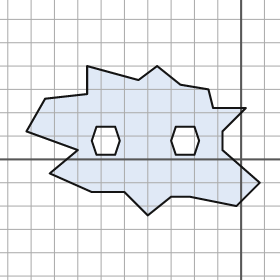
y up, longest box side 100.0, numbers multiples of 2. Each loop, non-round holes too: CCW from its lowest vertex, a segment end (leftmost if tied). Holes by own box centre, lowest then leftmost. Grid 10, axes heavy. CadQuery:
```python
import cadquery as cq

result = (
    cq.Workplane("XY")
    .moveTo(-40.0, -24.0)
    .lineTo(-30.0, -16.0)
    .lineTo(-22.0, -16.0)
    .lineTo(-2.0, -20.0)
    .lineTo(8.0, -10.0)
    .lineTo(-8.0, 4.0)
    .lineTo(-8.0, 12.0)
    .lineTo(2.0, 22.0)
    .lineTo(-12.0, 22.0)
    .lineTo(-14.0, 30.0)
    .lineTo(-26.0, 32.0)
    .lineTo(-36.0, 40.0)
    .lineTo(-44.0, 34.0)
    .lineTo(-66.0, 40.0)
    .lineTo(-66.0, 28.0)
    .lineTo(-84.0, 26.0)
    .lineTo(-92.0, 12.0)
    .lineTo(-70.0, 4.0)
    .lineTo(-82.0, -6.0)
    .lineTo(-64.0, -14.0)
    .lineTo(-50.0, -14.0)
    .close()
    .moveTo(-62.0, 2.0)
    .lineTo(-54.0, 2.0)
    .lineTo(-52.0, 8.0)
    .lineTo(-54.0, 14.0)
    .lineTo(-62.0, 14.0)
    .lineTo(-64.0, 8.0)
    .close()
    .moveTo(-28.0, 2.0)
    .lineTo(-20.0, 2.0)
    .lineTo(-18.0, 8.0)
    .lineTo(-20.0, 14.0)
    .lineTo(-28.0, 14.0)
    .lineTo(-30.0, 8.0)
    .close()
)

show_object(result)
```